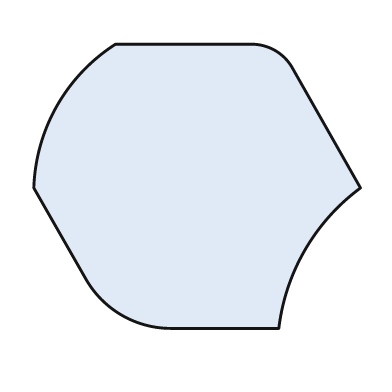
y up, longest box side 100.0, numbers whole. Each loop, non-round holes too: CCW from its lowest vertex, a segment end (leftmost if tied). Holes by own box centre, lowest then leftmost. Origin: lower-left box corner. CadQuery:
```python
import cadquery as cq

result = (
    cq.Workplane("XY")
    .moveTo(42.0, 0.0)
    .lineTo(75.0, 0.0)
    .threePointArc((83.0, 24.0), (100.0, 43.0))
    .lineTo(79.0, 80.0)
    .threePointArc((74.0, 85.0), (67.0, 87.0))
    .lineTo(25.0, 87.0)
    .threePointArc((7.0, 68.0), (0.0, 43.0))
    .lineTo(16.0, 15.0)
    .threePointArc((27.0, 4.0), (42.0, 0.0))
    .close()
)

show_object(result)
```